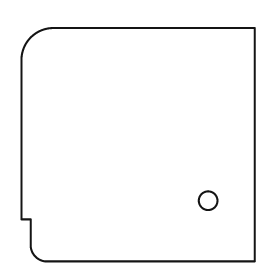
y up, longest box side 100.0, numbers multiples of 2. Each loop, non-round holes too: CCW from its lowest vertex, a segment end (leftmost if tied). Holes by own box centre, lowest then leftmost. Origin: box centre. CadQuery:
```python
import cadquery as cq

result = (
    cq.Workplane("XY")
    .moveTo(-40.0, -50.0)
    .lineTo(50.0, -50.0)
    .lineTo(50.0, 50.0)
    .lineTo(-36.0, 50.0)
    .threePointArc((-46.0, 46.0), (-50.0, 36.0))
    .lineTo(-50.0, -32.0)
    .lineTo(-46.0, -32.0)
    .lineTo(-46.0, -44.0)
    .threePointArc((-44.0, -48.0), (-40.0, -50.0))
    .close()
    .moveTo(30.0, -24.0)
    .circle(4.0)
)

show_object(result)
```